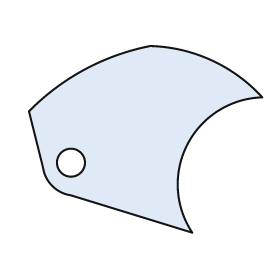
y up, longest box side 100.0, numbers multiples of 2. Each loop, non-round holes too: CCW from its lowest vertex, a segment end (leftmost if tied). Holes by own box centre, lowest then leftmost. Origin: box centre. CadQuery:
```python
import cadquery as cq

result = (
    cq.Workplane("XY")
    .moveTo(20.0, -40.0)
    .threePointArc((18.0, -2.0), (50.0, 18.0))
    .threePointArc((28.0, 34.0), (2.0, 40.0))
    .threePointArc((-26.0, 30.0), (-50.0, 12.0))
    .lineTo(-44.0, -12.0)
    .threePointArc((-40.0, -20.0), (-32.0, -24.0))
    .close()
    .moveTo(-32.0, -10.0)
    .circle(6.0)
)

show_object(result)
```